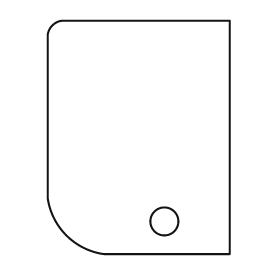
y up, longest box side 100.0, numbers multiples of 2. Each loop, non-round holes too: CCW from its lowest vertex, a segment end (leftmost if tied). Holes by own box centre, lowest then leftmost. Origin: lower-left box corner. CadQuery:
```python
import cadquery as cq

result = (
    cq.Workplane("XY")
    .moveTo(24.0, 0.0)
    .lineTo(78.0, 0.0)
    .lineTo(78.0, 100.0)
    .lineTo(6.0, 100.0)
    .threePointArc((2.0, 98.0), (0.0, 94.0))
    .lineTo(0.0, 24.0)
    .threePointArc((8.0, 8.0), (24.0, 0.0))
    .close()
    .moveTo(50.0, 14.0)
    .circle(6.0)
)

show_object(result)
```